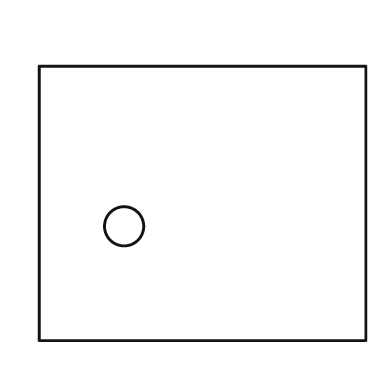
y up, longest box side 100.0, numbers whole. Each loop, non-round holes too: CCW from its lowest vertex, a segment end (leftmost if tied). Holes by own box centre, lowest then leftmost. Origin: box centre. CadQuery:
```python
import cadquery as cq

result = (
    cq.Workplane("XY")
    .moveTo(-50.0, -42.0)
    .lineTo(50.0, -42.0)
    .lineTo(50.0, 42.0)
    .lineTo(-50.0, 42.0)
    .close()
    .moveTo(-24.0, -7.0)
    .circle(6.0)
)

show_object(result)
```